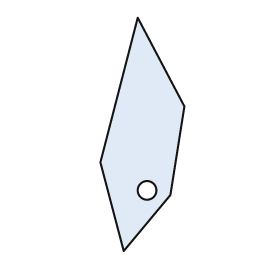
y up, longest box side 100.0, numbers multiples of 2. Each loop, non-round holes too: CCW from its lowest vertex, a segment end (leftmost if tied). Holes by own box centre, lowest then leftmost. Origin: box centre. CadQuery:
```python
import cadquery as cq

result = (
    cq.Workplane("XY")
    .moveTo(-8.0, -50.0)
    .lineTo(12.0, -26.0)
    .lineTo(18.0, 12.0)
    .lineTo(-2.0, 50.0)
    .lineTo(-18.0, -12.0)
    .close()
    .moveTo(2.0, -24.0)
    .circle(4.0)
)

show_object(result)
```